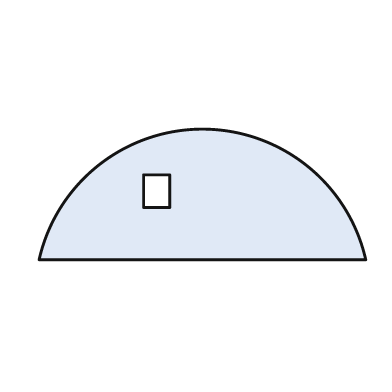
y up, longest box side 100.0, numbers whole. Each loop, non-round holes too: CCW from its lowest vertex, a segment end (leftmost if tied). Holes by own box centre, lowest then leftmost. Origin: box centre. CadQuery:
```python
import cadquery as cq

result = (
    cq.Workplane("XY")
    .moveTo(-50.0, -20.0)
    .lineTo(50.0, -20.0)
    .threePointArc((0.0, 20.0), (-50.0, -20.0))
    .close()
    .moveTo(-18.0, -4.0)
    .lineTo(-10.0, -4.0)
    .lineTo(-10.0, 6.0)
    .lineTo(-18.0, 6.0)
    .close()
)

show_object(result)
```